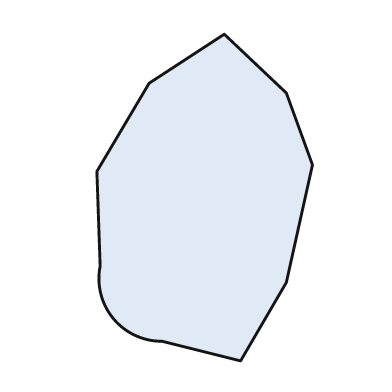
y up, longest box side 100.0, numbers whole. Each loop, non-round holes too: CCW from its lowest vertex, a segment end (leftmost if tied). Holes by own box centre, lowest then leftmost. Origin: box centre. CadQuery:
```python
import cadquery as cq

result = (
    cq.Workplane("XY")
    .moveTo(11.0, -50.0)
    .lineTo(25.0, -26.0)
    .lineTo(33.0, 10.0)
    .lineTo(25.0, 32.0)
    .lineTo(6.0, 50.0)
    .lineTo(-17.0, 35.0)
    .lineTo(-33.0, 8.0)
    .lineTo(-32.0, -21.0)
    .threePointArc((-28.0, -37.0), (-13.0, -44.0))
    .close()
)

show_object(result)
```